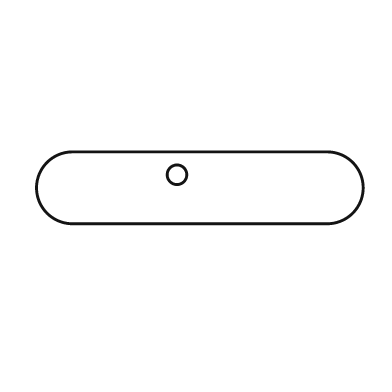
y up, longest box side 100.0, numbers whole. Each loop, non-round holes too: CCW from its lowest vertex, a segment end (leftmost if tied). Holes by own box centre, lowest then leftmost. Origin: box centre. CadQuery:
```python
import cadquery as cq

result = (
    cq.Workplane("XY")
    .moveTo(-39.0, -11.0)
    .lineTo(39.0, -11.0)
    .threePointArc((50.0, 0.0), (39.0, 11.0))
    .lineTo(-39.0, 11.0)
    .threePointArc((-50.0, 0.0), (-39.0, -11.0))
    .close()
    .moveTo(-7.0, 4.0)
    .circle(3.0)
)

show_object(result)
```